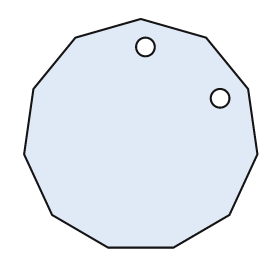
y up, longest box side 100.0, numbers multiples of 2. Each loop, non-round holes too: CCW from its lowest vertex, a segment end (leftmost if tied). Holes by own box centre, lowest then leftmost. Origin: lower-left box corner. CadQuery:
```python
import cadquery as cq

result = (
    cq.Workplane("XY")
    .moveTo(36.0, 0.0)
    .lineTo(64.0, 0.0)
    .lineTo(88.0, 14.0)
    .lineTo(100.0, 40.0)
    .lineTo(96.0, 68.0)
    .lineTo(78.0, 90.0)
    .lineTo(50.0, 98.0)
    .lineTo(22.0, 90.0)
    .lineTo(4.0, 68.0)
    .lineTo(0.0, 40.0)
    .lineTo(12.0, 14.0)
    .close()
    .moveTo(84.0, 64.0)
    .circle(4.0)
    .moveTo(52.0, 86.0)
    .circle(4.0)
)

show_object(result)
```